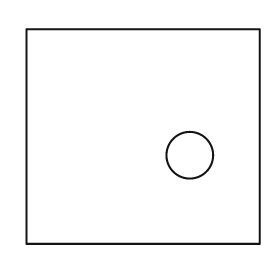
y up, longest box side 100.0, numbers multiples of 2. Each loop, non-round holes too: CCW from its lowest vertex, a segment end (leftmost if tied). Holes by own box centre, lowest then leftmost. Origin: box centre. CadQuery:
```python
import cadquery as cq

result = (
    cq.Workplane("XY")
    .moveTo(-50.0, -46.0)
    .lineTo(50.0, -46.0)
    .lineTo(50.0, 46.0)
    .lineTo(-50.0, 46.0)
    .close()
    .moveTo(20.0, -8.0)
    .circle(10.0)
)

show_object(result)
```